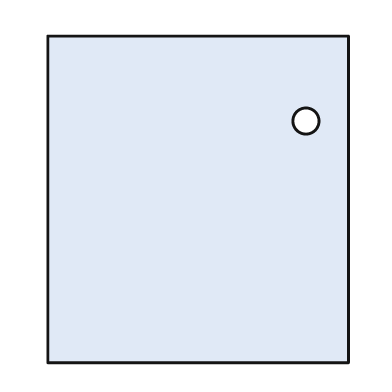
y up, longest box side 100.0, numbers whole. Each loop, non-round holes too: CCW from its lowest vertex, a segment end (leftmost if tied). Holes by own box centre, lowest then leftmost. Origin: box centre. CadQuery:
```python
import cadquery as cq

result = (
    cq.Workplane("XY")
    .moveTo(-46.0, -50.0)
    .lineTo(46.0, -50.0)
    .lineTo(46.0, 50.0)
    .lineTo(-46.0, 50.0)
    .close()
    .moveTo(33.0, 24.0)
    .circle(4.0)
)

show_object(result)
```